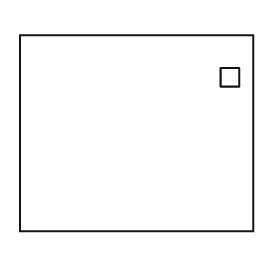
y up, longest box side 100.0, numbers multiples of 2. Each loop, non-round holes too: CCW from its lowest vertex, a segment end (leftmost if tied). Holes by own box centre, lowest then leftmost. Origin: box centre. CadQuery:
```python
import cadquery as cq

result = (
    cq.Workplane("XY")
    .moveTo(-50.0, -42.0)
    .lineTo(50.0, -42.0)
    .lineTo(50.0, 42.0)
    .lineTo(-50.0, 42.0)
    .close()
    .moveTo(36.0, 20.0)
    .lineTo(44.0, 20.0)
    .lineTo(44.0, 28.0)
    .lineTo(36.0, 28.0)
    .close()
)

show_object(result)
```